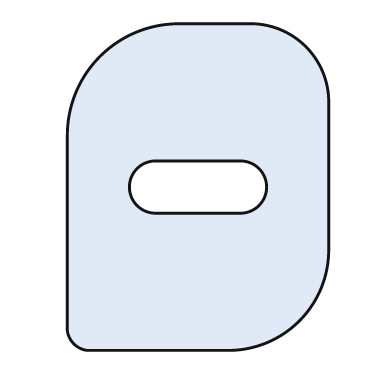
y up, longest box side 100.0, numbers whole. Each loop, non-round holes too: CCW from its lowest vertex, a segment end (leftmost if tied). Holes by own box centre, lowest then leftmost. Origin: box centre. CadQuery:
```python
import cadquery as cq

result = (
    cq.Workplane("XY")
    .moveTo(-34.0, -50.0)
    .lineTo(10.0, -50.0)
    .threePointArc((31.0, -41.0), (40.0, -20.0))
    .lineTo(40.0, 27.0)
    .threePointArc((33.0, 43.0), (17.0, 50.0))
    .lineTo(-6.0, 50.0)
    .threePointArc((-30.0, 40.0), (-40.0, 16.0))
    .lineTo(-40.0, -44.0)
    .threePointArc((-38.0, -48.0), (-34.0, -50.0))
    .close()
    .moveTo(-13.0, -8.0)
    .lineTo(13.0, -8.0)
    .threePointArc((21.0, 0.0), (13.0, 8.0))
    .lineTo(-13.0, 8.0)
    .threePointArc((-21.0, 0.0), (-13.0, -8.0))
    .close()
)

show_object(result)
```